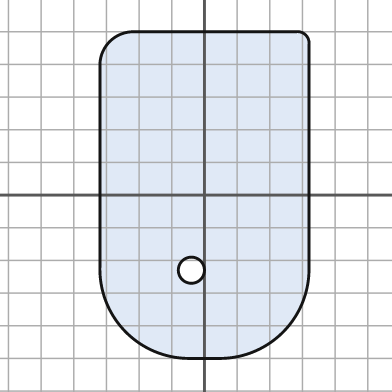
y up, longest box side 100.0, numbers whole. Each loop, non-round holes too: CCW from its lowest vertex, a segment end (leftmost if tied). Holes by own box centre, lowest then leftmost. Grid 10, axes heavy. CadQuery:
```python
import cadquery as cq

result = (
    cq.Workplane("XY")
    .moveTo(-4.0, -50.0)
    .lineTo(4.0, -50.0)
    .threePointArc((24.0, -42.0), (32.0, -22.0))
    .lineTo(32.0, 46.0)
    .threePointArc((31.0, 49.0), (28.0, 50.0))
    .lineTo(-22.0, 50.0)
    .threePointArc((-29.0, 47.0), (-32.0, 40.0))
    .lineTo(-32.0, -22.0)
    .threePointArc((-24.0, -42.0), (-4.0, -50.0))
    .close()
    .moveTo(-4.0, -23.0)
    .circle(4.0)
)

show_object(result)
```